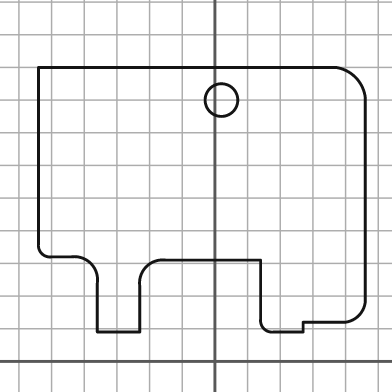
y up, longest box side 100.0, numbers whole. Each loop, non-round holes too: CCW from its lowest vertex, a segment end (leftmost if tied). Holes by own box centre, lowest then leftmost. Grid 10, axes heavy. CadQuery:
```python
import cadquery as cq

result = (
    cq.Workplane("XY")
    .moveTo(-36.0, 9.0)
    .lineTo(-23.0, 9.0)
    .lineTo(-23.0, 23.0)
    .threePointArc((-21.0, 29.0), (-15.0, 31.0))
    .lineTo(14.0, 31.0)
    .lineTo(14.0, 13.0)
    .threePointArc((15.0, 10.0), (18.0, 9.0))
    .lineTo(27.0, 9.0)
    .lineTo(27.0, 12.0)
    .lineTo(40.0, 12.0)
    .threePointArc((44.0, 14.0), (46.0, 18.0))
    .lineTo(46.0, 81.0)
    .threePointArc((43.0, 87.0), (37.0, 90.0))
    .lineTo(-54.0, 90.0)
    .lineTo(-54.0, 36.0)
    .threePointArc((-53.0, 33.0), (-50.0, 32.0))
    .lineTo(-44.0, 32.0)
    .threePointArc((-38.0, 30.0), (-36.0, 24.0))
    .close()
    .moveTo(2.0, 80.0)
    .circle(5.0)
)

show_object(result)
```